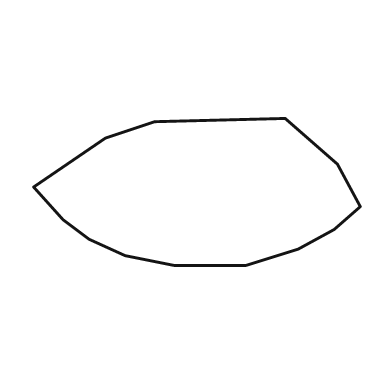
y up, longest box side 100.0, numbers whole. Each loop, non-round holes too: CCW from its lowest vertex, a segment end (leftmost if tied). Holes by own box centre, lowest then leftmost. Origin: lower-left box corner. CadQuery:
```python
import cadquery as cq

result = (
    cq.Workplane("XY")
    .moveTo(43.0, 0.0)
    .lineTo(65.0, 0.0)
    .lineTo(81.0, 5.0)
    .lineTo(92.0, 11.0)
    .lineTo(100.0, 18.0)
    .lineTo(93.0, 31.0)
    .lineTo(77.0, 45.0)
    .lineTo(37.0, 44.0)
    .lineTo(22.0, 39.0)
    .lineTo(0.0, 24.0)
    .lineTo(9.0, 14.0)
    .lineTo(17.0, 8.0)
    .lineTo(28.0, 3.0)
    .close()
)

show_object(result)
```